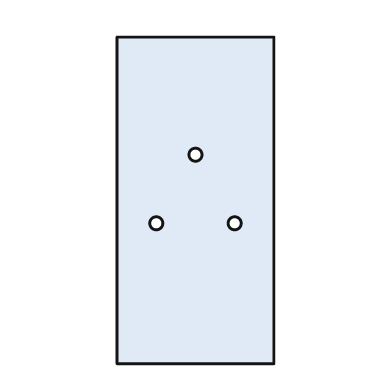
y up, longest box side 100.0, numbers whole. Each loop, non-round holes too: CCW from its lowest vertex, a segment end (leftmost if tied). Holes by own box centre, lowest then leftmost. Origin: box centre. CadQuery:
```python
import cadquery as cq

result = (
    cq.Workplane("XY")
    .moveTo(-24.0, -50.0)
    .lineTo(24.0, -50.0)
    .lineTo(24.0, 50.0)
    .lineTo(-24.0, 50.0)
    .close()
    .moveTo(-12.0, -7.0)
    .circle(2.0)
    .moveTo(12.0, -7.0)
    .circle(2.0)
    .moveTo(0.0, 14.0)
    .circle(2.0)
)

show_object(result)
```